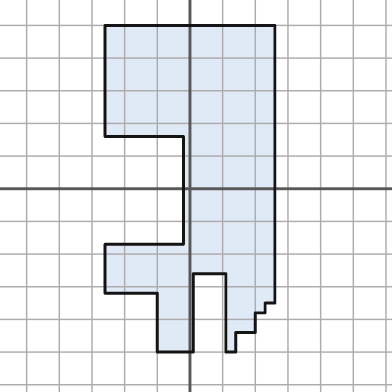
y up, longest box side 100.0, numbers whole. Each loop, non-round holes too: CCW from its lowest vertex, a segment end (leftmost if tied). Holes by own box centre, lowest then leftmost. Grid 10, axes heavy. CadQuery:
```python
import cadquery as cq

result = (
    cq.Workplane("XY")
    .moveTo(-10.0, -50.0)
    .lineTo(1.0, -50.0)
    .lineTo(1.0, -26.0)
    .lineTo(11.0, -26.0)
    .lineTo(11.0, -50.0)
    .lineTo(14.0, -50.0)
    .lineTo(14.0, -44.0)
    .lineTo(20.0, -44.0)
    .lineTo(20.0, -38.0)
    .lineTo(23.0, -38.0)
    .lineTo(23.0, -35.0)
    .lineTo(26.0, -35.0)
    .lineTo(26.0, 50.0)
    .lineTo(-26.0, 50.0)
    .lineTo(-26.0, 16.0)
    .lineTo(-2.0, 16.0)
    .lineTo(-2.0, -17.0)
    .lineTo(-26.0, -17.0)
    .lineTo(-26.0, -32.0)
    .lineTo(-10.0, -32.0)
    .close()
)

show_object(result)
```